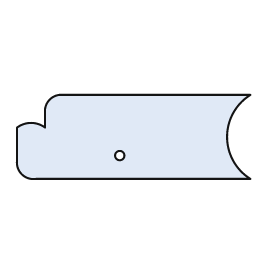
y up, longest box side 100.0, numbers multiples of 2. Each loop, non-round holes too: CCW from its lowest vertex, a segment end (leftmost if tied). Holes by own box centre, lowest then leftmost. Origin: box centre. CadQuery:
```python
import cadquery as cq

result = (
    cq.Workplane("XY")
    .moveTo(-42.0, -18.0)
    .lineTo(50.0, -18.0)
    .threePointArc((40.0, 0.0), (50.0, 18.0))
    .lineTo(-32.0, 18.0)
    .threePointArc((-36.0, 16.0), (-38.0, 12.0))
    .lineTo(-38.0, 4.0)
    .threePointArc((-44.0, 6.0), (-50.0, 4.0))
    .lineTo(-50.0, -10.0)
    .threePointArc((-48.0, -16.0), (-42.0, -18.0))
    .close()
    .moveTo(-6.0, -8.0)
    .circle(2.0)
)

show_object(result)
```